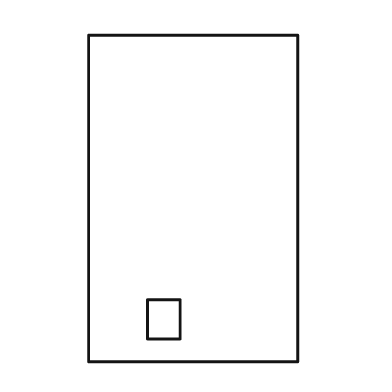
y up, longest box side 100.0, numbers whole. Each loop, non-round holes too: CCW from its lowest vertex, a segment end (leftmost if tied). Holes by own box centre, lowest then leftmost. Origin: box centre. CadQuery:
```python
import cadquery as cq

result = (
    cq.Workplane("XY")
    .moveTo(-32.0, -50.0)
    .lineTo(32.0, -50.0)
    .lineTo(32.0, 50.0)
    .lineTo(-32.0, 50.0)
    .close()
    .moveTo(-14.0, -43.0)
    .lineTo(-4.0, -43.0)
    .lineTo(-4.0, -31.0)
    .lineTo(-14.0, -31.0)
    .close()
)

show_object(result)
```